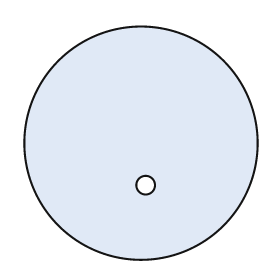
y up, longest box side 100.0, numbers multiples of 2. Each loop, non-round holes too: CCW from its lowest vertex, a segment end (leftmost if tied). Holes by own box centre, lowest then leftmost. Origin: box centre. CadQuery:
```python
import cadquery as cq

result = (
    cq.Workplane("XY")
    .moveTo(0.0, 0.0)
    .circle(50.0)
    .moveTo(2.0, -18.0)
    .circle(4.0)
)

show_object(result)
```